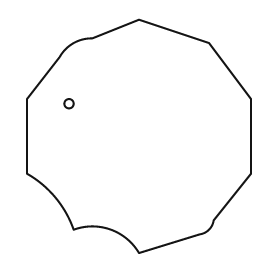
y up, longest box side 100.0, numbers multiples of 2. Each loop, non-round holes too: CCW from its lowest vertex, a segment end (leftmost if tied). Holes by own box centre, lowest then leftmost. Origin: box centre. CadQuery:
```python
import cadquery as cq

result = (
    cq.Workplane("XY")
    .moveTo(0.0, -50.0)
    .lineTo(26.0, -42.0)
    .threePointArc((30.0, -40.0), (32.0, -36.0))
    .lineTo(48.0, -16.0)
    .lineTo(48.0, 16.0)
    .lineTo(30.0, 40.0)
    .lineTo(0.0, 50.0)
    .lineTo(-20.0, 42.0)
    .threePointArc((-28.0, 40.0), (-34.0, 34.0))
    .lineTo(-48.0, 16.0)
    .lineTo(-48.0, -16.0)
    .threePointArc((-36.0, -26.0), (-28.0, -40.0))
    .threePointArc((-12.0, -40.0), (0.0, -50.0))
    .close()
    .moveTo(-30.0, 14.0)
    .circle(2.0)
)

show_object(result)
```